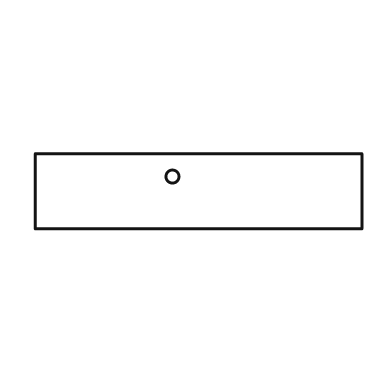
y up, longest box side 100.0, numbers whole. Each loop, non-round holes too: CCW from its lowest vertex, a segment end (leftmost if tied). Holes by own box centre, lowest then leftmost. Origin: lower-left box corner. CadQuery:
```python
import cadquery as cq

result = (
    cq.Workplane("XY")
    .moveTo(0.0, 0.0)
    .lineTo(100.0, 0.0)
    .lineTo(100.0, 23.0)
    .lineTo(0.0, 23.0)
    .close()
    .moveTo(42.0, 16.0)
    .circle(2.0)
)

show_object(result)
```